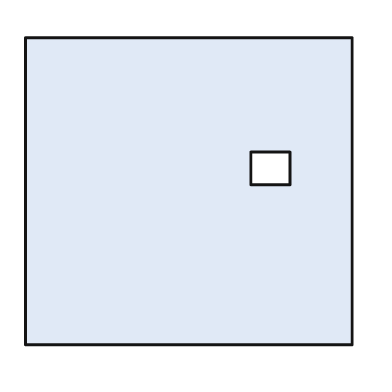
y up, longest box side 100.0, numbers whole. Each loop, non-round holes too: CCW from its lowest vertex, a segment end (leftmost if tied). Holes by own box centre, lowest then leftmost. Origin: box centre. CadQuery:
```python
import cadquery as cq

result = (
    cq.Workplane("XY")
    .moveTo(-50.0, -47.0)
    .lineTo(50.0, -47.0)
    .lineTo(50.0, 47.0)
    .lineTo(-50.0, 47.0)
    .close()
    .moveTo(19.0, 2.0)
    .lineTo(31.0, 2.0)
    .lineTo(31.0, 12.0)
    .lineTo(19.0, 12.0)
    .close()
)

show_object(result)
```